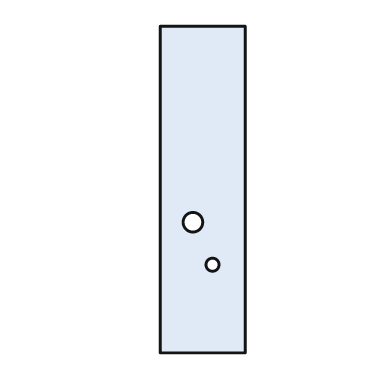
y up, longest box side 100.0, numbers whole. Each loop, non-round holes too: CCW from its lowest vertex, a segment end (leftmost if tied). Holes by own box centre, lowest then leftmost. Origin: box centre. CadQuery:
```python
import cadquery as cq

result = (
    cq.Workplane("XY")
    .moveTo(-13.0, -50.0)
    .lineTo(13.0, -50.0)
    .lineTo(13.0, 50.0)
    .lineTo(-13.0, 50.0)
    .close()
    .moveTo(3.0, -23.0)
    .circle(2.0)
    .moveTo(-3.0, -10.0)
    .circle(3.0)
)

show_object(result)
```